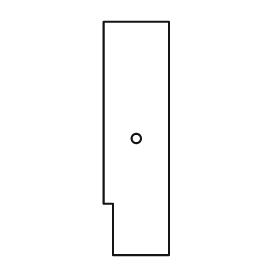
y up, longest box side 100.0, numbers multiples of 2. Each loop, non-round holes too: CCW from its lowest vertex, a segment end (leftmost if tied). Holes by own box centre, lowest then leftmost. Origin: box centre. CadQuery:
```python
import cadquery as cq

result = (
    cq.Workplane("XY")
    .moveTo(-10.0, -50.0)
    .lineTo(14.0, -50.0)
    .lineTo(14.0, 50.0)
    .lineTo(-14.0, 50.0)
    .lineTo(-14.0, -28.0)
    .lineTo(-10.0, -28.0)
    .close()
    .moveTo(0.0, 0.0)
    .circle(2.0)
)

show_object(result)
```